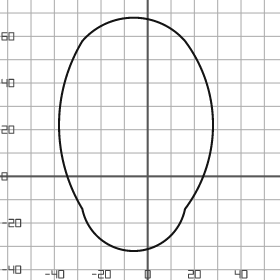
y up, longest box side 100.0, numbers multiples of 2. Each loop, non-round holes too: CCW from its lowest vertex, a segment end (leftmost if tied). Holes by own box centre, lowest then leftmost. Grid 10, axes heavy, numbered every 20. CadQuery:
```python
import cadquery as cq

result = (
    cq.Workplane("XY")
    .moveTo(-28.0, -14.0)
    .threePointArc((-6.0, -32.0), (16.0, -14.0))
    .threePointArc((28.0, 22.0), (16.0, 58.0))
    .threePointArc((-6.0, 68.0), (-28.0, 58.0))
    .threePointArc((-38.0, 22.0), (-28.0, -14.0))
    .close()
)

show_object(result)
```